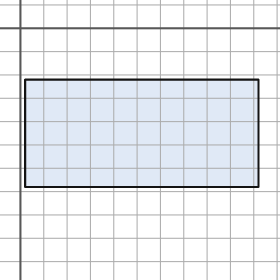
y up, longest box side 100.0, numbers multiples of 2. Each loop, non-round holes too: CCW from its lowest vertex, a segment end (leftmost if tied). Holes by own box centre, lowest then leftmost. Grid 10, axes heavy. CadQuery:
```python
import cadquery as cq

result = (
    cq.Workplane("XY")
    .moveTo(2.0, -68.0)
    .lineTo(102.0, -68.0)
    .lineTo(102.0, -22.0)
    .lineTo(2.0, -22.0)
    .close()
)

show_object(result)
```